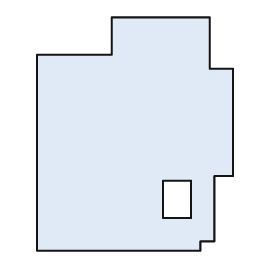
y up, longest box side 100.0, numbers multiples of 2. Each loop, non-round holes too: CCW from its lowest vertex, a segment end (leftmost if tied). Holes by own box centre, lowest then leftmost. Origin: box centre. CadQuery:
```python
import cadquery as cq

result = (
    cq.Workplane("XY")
    .moveTo(-42.0, -50.0)
    .lineTo(28.0, -50.0)
    .lineTo(28.0, -46.0)
    .lineTo(34.0, -46.0)
    .lineTo(34.0, -18.0)
    .lineTo(42.0, -18.0)
    .lineTo(42.0, 28.0)
    .lineTo(32.0, 28.0)
    .lineTo(32.0, 50.0)
    .lineTo(-10.0, 50.0)
    .lineTo(-10.0, 34.0)
    .lineTo(-42.0, 34.0)
    .close()
    .moveTo(12.0, -36.0)
    .lineTo(24.0, -36.0)
    .lineTo(24.0, -20.0)
    .lineTo(12.0, -20.0)
    .close()
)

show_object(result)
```